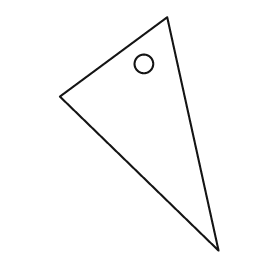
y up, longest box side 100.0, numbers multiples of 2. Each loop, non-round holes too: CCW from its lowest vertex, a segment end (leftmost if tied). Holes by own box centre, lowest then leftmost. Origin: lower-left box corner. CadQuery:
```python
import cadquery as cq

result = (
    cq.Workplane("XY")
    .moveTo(68.0, 0.0)
    .lineTo(46.0, 100.0)
    .lineTo(0.0, 66.0)
    .close()
    .moveTo(36.0, 80.0)
    .circle(4.0)
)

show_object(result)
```